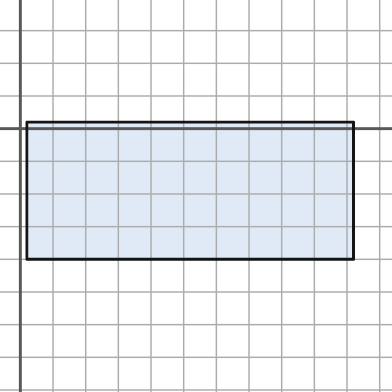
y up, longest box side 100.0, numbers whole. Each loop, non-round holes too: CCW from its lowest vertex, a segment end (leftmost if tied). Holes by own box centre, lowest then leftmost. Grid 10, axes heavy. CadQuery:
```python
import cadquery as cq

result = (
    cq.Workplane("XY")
    .moveTo(2.0, -40.0)
    .lineTo(102.0, -40.0)
    .lineTo(102.0, 2.0)
    .lineTo(2.0, 2.0)
    .close()
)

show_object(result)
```